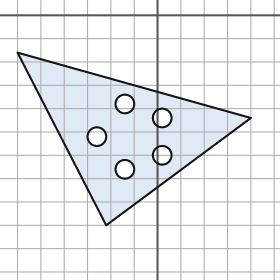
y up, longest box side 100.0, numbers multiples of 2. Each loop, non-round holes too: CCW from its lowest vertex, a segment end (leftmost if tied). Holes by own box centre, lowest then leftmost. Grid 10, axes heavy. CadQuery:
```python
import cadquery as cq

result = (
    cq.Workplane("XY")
    .moveTo(-22.0, -90.0)
    .lineTo(40.0, -44.0)
    .lineTo(-60.0, -16.0)
    .close()
    .moveTo(-14.0, -66.0)
    .circle(4.0)
    .moveTo(2.0, -60.0)
    .circle(4.0)
    .moveTo(-26.0, -52.0)
    .circle(4.0)
    .moveTo(2.0, -44.0)
    .circle(4.0)
    .moveTo(-14.0, -38.0)
    .circle(4.0)
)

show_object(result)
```